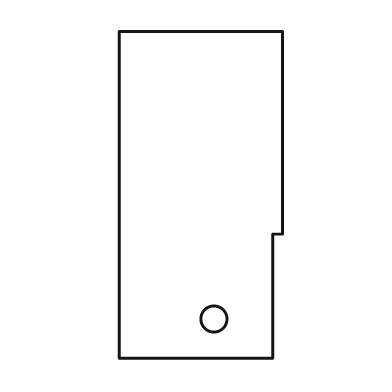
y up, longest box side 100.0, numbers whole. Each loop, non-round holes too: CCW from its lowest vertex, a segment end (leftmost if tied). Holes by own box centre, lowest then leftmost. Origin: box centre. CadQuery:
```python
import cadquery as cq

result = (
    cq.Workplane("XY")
    .moveTo(-25.0, -50.0)
    .lineTo(22.0, -50.0)
    .lineTo(22.0, -12.0)
    .lineTo(25.0, -12.0)
    .lineTo(25.0, 50.0)
    .lineTo(-25.0, 50.0)
    .close()
    .moveTo(4.0, -38.0)
    .circle(4.0)
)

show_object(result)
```